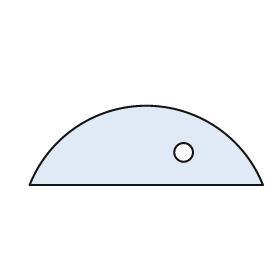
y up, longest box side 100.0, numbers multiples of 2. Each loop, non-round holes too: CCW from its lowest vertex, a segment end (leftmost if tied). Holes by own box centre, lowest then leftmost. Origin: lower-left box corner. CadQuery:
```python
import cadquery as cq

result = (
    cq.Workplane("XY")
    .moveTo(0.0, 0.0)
    .lineTo(100.0, 0.0)
    .threePointArc((50.0, 34.0), (0.0, 0.0))
    .close()
    .moveTo(66.0, 14.0)
    .circle(4.0)
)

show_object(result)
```